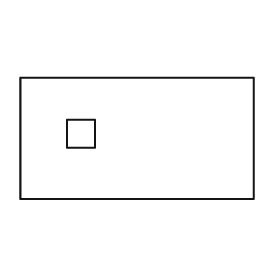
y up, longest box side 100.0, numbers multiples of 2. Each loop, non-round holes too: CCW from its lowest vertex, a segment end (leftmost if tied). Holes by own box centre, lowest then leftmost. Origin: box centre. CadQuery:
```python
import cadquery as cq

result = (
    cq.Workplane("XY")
    .moveTo(-50.0, -26.0)
    .lineTo(50.0, -26.0)
    .lineTo(50.0, 26.0)
    .lineTo(-50.0, 26.0)
    .close()
    .moveTo(-30.0, -4.0)
    .lineTo(-18.0, -4.0)
    .lineTo(-18.0, 8.0)
    .lineTo(-30.0, 8.0)
    .close()
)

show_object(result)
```